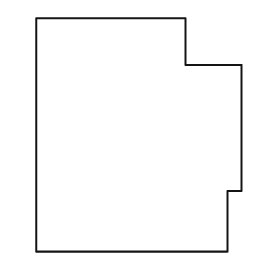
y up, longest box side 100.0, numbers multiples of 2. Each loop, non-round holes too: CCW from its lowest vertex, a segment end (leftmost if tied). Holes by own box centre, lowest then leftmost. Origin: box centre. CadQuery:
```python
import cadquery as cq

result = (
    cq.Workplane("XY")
    .moveTo(-44.0, -50.0)
    .lineTo(38.0, -50.0)
    .lineTo(38.0, -24.0)
    .lineTo(44.0, -24.0)
    .lineTo(44.0, 30.0)
    .lineTo(20.0, 30.0)
    .lineTo(20.0, 50.0)
    .lineTo(-44.0, 50.0)
    .close()
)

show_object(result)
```